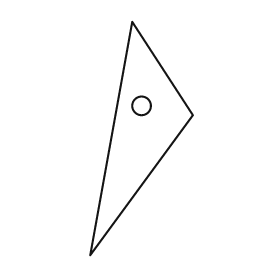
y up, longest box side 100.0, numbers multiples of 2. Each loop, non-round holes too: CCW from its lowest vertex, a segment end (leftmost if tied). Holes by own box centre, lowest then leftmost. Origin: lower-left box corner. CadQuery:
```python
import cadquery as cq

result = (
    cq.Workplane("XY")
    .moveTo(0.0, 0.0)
    .lineTo(44.0, 60.0)
    .lineTo(18.0, 100.0)
    .close()
    .moveTo(22.0, 64.0)
    .circle(4.0)
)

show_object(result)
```